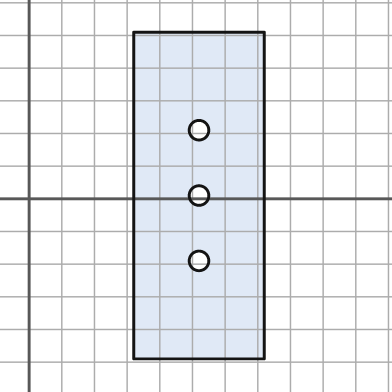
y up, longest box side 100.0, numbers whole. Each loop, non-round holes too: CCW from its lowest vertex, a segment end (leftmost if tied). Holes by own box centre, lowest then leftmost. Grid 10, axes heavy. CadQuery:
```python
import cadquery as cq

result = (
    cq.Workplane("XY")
    .moveTo(32.0, -49.0)
    .lineTo(72.0, -49.0)
    .lineTo(72.0, 51.0)
    .lineTo(32.0, 51.0)
    .close()
    .moveTo(52.0, -19.0)
    .circle(3.0)
    .moveTo(52.0, 1.0)
    .circle(3.0)
    .moveTo(52.0, 21.0)
    .circle(3.0)
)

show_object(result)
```